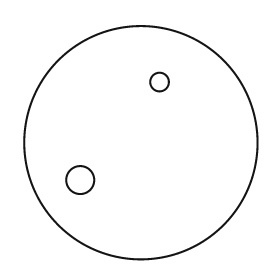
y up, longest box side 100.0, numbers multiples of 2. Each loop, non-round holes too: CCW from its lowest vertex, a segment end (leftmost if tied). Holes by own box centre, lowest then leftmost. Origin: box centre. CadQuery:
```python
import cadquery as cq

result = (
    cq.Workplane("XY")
    .moveTo(0.0, 0.0)
    .circle(50.0)
    .moveTo(-26.0, -16.0)
    .circle(6.0)
    .moveTo(8.0, 26.0)
    .circle(4.0)
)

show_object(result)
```